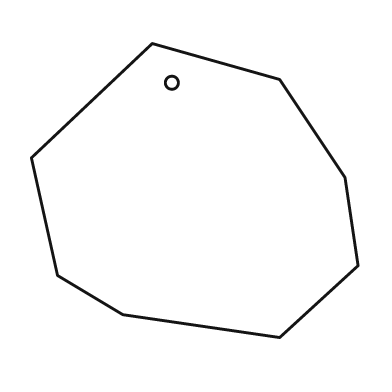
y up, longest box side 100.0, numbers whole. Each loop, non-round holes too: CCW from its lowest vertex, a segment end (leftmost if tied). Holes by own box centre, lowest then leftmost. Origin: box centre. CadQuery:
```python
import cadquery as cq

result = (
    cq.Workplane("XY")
    .moveTo(26.0, -45.0)
    .lineTo(50.0, -23.0)
    .lineTo(46.0, 4.0)
    .lineTo(26.0, 34.0)
    .lineTo(-13.0, 45.0)
    .lineTo(-50.0, 10.0)
    .lineTo(-42.0, -26.0)
    .lineTo(-22.0, -38.0)
    .close()
    .moveTo(-7.0, 33.0)
    .circle(2.0)
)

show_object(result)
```